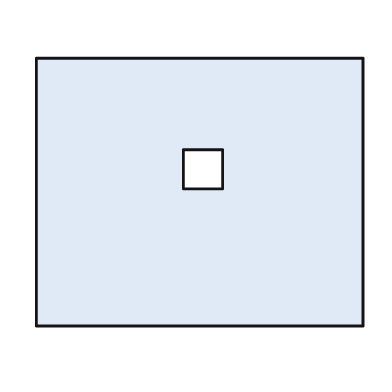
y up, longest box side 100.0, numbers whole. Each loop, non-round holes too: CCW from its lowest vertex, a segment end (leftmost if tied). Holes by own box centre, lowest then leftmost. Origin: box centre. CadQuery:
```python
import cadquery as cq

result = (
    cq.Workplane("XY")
    .moveTo(-50.0, -41.0)
    .lineTo(50.0, -41.0)
    .lineTo(50.0, 41.0)
    .lineTo(-50.0, 41.0)
    .close()
    .moveTo(-5.0, 1.0)
    .lineTo(7.0, 1.0)
    .lineTo(7.0, 13.0)
    .lineTo(-5.0, 13.0)
    .close()
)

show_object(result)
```